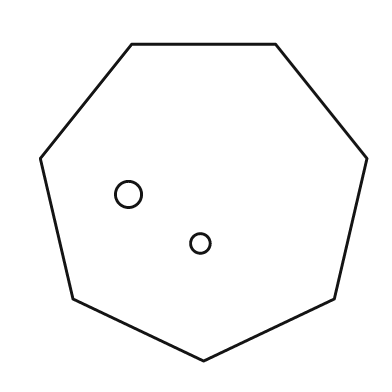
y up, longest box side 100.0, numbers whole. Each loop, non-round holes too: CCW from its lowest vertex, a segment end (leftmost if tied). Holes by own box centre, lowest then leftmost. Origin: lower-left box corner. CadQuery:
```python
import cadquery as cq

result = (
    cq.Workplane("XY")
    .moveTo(50.0, 0.0)
    .lineTo(90.0, 19.0)
    .lineTo(100.0, 62.0)
    .lineTo(72.0, 97.0)
    .lineTo(28.0, 97.0)
    .lineTo(0.0, 62.0)
    .lineTo(10.0, 19.0)
    .close()
    .moveTo(49.0, 36.0)
    .circle(3.0)
    .moveTo(27.0, 51.0)
    .circle(4.0)
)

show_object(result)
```